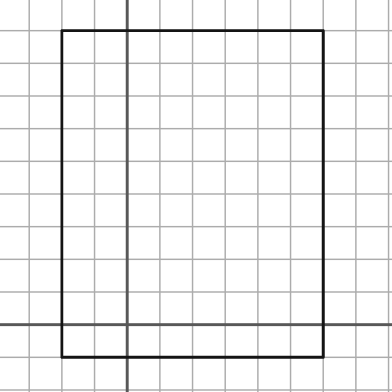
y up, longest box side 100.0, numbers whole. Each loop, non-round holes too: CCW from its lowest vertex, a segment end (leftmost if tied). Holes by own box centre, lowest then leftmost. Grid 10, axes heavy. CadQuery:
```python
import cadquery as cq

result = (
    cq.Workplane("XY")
    .moveTo(-20.0, -10.0)
    .lineTo(60.0, -10.0)
    .lineTo(60.0, 90.0)
    .lineTo(-20.0, 90.0)
    .close()
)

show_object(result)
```